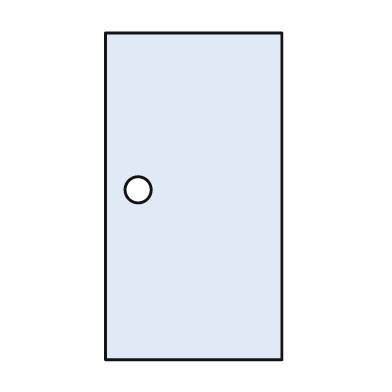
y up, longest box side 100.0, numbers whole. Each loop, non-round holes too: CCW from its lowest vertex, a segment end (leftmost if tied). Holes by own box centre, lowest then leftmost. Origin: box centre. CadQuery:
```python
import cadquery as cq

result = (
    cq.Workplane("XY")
    .moveTo(-27.0, -50.0)
    .lineTo(27.0, -50.0)
    .lineTo(27.0, 50.0)
    .lineTo(-27.0, 50.0)
    .close()
    .moveTo(-17.0, 2.0)
    .circle(4.0)
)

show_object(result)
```